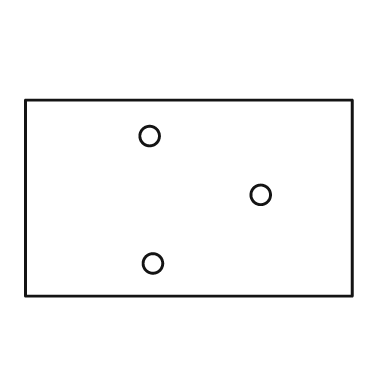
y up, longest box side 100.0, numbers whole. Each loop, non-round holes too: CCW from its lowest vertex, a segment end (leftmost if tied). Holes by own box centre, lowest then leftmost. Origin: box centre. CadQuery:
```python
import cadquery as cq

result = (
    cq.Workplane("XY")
    .moveTo(-50.0, -30.0)
    .lineTo(50.0, -30.0)
    .lineTo(50.0, 30.0)
    .lineTo(-50.0, 30.0)
    .close()
    .moveTo(-11.0, -20.0)
    .circle(3.0)
    .moveTo(22.0, 1.0)
    .circle(3.0)
    .moveTo(-12.0, 19.0)
    .circle(3.0)
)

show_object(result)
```